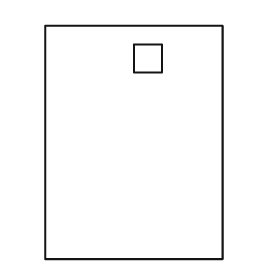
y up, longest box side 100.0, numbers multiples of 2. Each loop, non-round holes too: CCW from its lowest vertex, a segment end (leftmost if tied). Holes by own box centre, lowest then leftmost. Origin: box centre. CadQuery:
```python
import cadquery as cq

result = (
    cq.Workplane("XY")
    .moveTo(-38.0, -50.0)
    .lineTo(38.0, -50.0)
    .lineTo(38.0, 50.0)
    .lineTo(-38.0, 50.0)
    .close()
    .moveTo(0.0, 30.0)
    .lineTo(12.0, 30.0)
    .lineTo(12.0, 42.0)
    .lineTo(0.0, 42.0)
    .close()
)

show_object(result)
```